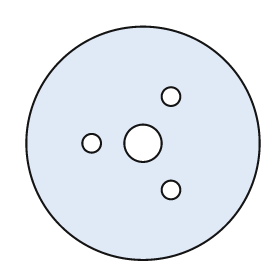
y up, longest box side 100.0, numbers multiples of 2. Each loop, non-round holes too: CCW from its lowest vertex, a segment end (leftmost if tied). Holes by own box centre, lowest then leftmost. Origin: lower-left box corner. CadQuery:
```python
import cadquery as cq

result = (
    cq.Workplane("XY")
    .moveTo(50.0, 50.0)
    .circle(50.0)
    .moveTo(62.0, 30.0)
    .circle(4.0)
    .moveTo(28.0, 50.0)
    .circle(4.0)
    .moveTo(50.0, 50.0)
    .circle(8.0)
    .moveTo(62.0, 70.0)
    .circle(4.0)
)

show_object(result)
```